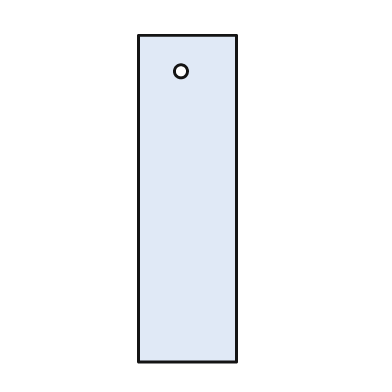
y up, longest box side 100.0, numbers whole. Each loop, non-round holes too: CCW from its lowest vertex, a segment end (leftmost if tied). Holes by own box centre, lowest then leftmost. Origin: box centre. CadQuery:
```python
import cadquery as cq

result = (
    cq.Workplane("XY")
    .moveTo(-15.0, -50.0)
    .lineTo(15.0, -50.0)
    .lineTo(15.0, 50.0)
    .lineTo(-15.0, 50.0)
    .close()
    .moveTo(-2.0, 39.0)
    .circle(2.0)
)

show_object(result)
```